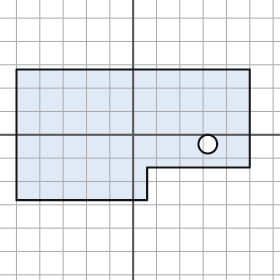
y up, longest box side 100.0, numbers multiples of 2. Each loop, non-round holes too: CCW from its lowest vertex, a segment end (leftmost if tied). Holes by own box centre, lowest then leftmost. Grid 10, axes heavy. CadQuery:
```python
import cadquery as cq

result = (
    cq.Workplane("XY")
    .moveTo(-50.0, -28.0)
    .lineTo(6.0, -28.0)
    .lineTo(6.0, -14.0)
    .lineTo(50.0, -14.0)
    .lineTo(50.0, 28.0)
    .lineTo(-50.0, 28.0)
    .close()
    .moveTo(32.0, -4.0)
    .circle(4.0)
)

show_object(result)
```